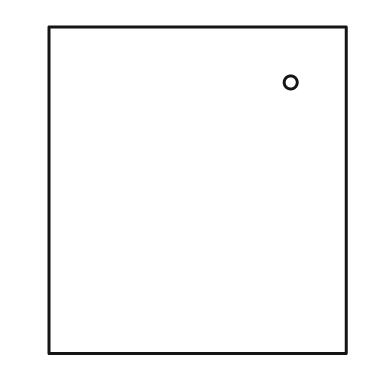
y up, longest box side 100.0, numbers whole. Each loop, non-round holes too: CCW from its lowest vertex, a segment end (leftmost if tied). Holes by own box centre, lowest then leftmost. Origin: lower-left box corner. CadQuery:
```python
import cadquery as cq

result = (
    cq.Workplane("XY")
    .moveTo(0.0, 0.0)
    .lineTo(91.0, 0.0)
    .lineTo(91.0, 100.0)
    .lineTo(0.0, 100.0)
    .close()
    .moveTo(74.0, 83.0)
    .circle(2.0)
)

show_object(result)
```